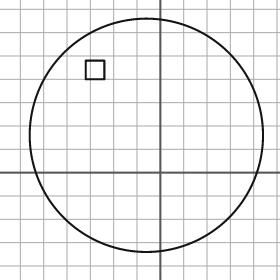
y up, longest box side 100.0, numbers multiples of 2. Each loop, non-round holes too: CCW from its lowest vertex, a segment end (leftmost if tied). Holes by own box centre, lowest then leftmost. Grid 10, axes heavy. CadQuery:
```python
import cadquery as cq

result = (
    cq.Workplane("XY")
    .moveTo(-6.0, 16.0)
    .circle(50.0)
    .moveTo(-32.0, 40.0)
    .lineTo(-24.0, 40.0)
    .lineTo(-24.0, 48.0)
    .lineTo(-32.0, 48.0)
    .close()
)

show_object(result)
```